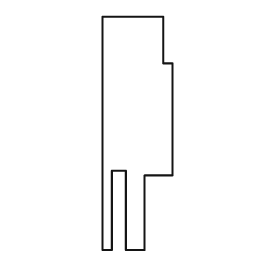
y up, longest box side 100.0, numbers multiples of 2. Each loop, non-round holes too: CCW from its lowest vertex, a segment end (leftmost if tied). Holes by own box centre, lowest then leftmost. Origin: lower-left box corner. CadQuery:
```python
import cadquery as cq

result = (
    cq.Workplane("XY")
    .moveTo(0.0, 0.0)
    .lineTo(4.0, 0.0)
    .lineTo(4.0, 34.0)
    .lineTo(10.0, 34.0)
    .lineTo(10.0, 0.0)
    .lineTo(18.0, 0.0)
    .lineTo(18.0, 32.0)
    .lineTo(30.0, 32.0)
    .lineTo(30.0, 80.0)
    .lineTo(26.0, 80.0)
    .lineTo(26.0, 100.0)
    .lineTo(0.0, 100.0)
    .close()
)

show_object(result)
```